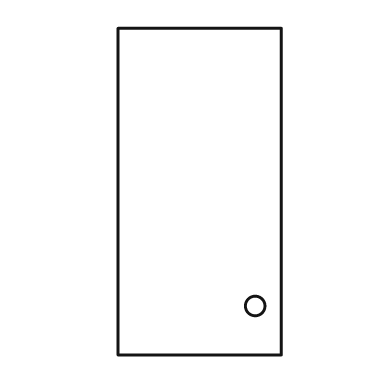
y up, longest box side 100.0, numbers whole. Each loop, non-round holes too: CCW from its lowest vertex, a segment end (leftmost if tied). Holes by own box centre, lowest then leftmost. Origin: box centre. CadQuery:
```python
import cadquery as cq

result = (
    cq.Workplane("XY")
    .moveTo(-25.0, -50.0)
    .lineTo(25.0, -50.0)
    .lineTo(25.0, 50.0)
    .lineTo(-25.0, 50.0)
    .close()
    .moveTo(17.0, -35.0)
    .circle(3.0)
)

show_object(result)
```